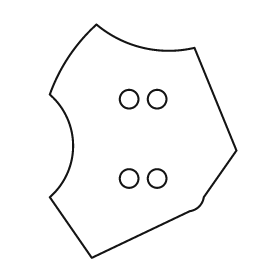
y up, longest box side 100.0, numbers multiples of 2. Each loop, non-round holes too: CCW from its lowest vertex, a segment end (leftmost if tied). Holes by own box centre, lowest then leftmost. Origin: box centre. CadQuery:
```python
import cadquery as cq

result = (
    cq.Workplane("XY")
    .moveTo(-22.0, -50.0)
    .lineTo(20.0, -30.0)
    .threePointArc((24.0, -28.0), (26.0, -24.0))
    .lineTo(40.0, -4.0)
    .lineTo(22.0, 40.0)
    .threePointArc((0.0, 40.0), (-20.0, 50.0))
    .threePointArc((-32.0, 36.0), (-40.0, 20.0))
    .threePointArc((-30.0, -2.0), (-40.0, -24.0))
    .close()
    .moveTo(-6.0, -16.0)
    .circle(4.0)
    .moveTo(6.0, -16.0)
    .circle(4.0)
    .moveTo(-6.0, 18.0)
    .circle(4.0)
    .moveTo(6.0, 18.0)
    .circle(4.0)
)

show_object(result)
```